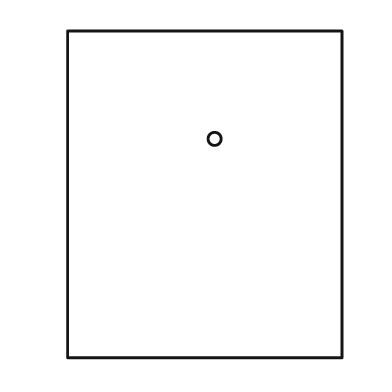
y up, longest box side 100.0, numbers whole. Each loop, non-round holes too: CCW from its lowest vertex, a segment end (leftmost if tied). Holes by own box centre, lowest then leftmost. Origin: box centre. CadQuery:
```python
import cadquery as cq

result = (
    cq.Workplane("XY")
    .moveTo(-42.0, -50.0)
    .lineTo(42.0, -50.0)
    .lineTo(42.0, 50.0)
    .lineTo(-42.0, 50.0)
    .close()
    .moveTo(3.0, 17.0)
    .circle(2.0)
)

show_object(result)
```